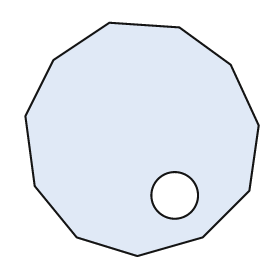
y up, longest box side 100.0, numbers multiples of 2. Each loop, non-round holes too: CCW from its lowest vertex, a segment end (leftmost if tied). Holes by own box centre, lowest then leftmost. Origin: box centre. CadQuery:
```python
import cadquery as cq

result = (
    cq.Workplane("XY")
    .moveTo(-2.0, -50.0)
    .lineTo(26.0, -42.0)
    .lineTo(46.0, -22.0)
    .lineTo(50.0, 6.0)
    .lineTo(38.0, 32.0)
    .lineTo(16.0, 48.0)
    .lineTo(-14.0, 50.0)
    .lineTo(-38.0, 34.0)
    .lineTo(-50.0, 10.0)
    .lineTo(-46.0, -20.0)
    .lineTo(-28.0, -42.0)
    .close()
    .moveTo(14.0, -24.0)
    .circle(10.0)
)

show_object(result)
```